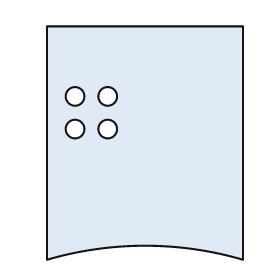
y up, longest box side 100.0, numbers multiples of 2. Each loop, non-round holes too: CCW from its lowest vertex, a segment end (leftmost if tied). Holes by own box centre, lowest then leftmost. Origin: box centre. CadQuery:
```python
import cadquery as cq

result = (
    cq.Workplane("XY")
    .moveTo(-42.0, -50.0)
    .threePointArc((0.0, -44.0), (42.0, -50.0))
    .lineTo(42.0, 50.0)
    .lineTo(-42.0, 50.0)
    .close()
    .moveTo(-30.0, 6.0)
    .circle(4.0)
    .moveTo(-16.0, 6.0)
    .circle(4.0)
    .moveTo(-30.0, 20.0)
    .circle(4.0)
    .moveTo(-16.0, 20.0)
    .circle(4.0)
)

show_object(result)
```